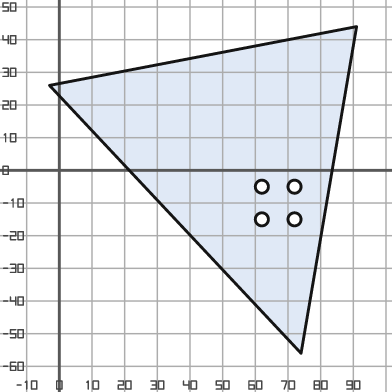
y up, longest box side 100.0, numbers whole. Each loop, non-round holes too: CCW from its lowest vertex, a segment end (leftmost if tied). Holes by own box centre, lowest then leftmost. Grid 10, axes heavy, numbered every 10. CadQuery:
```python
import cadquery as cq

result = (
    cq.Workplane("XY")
    .moveTo(74.0, -56.0)
    .lineTo(91.0, 44.0)
    .lineTo(-3.0, 26.0)
    .close()
    .moveTo(62.0, -15.0)
    .circle(2.0)
    .moveTo(72.0, -15.0)
    .circle(2.0)
    .moveTo(62.0, -5.0)
    .circle(2.0)
    .moveTo(72.0, -5.0)
    .circle(2.0)
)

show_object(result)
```